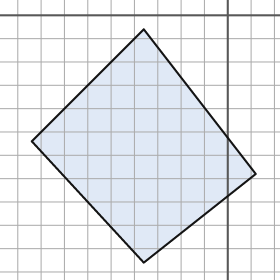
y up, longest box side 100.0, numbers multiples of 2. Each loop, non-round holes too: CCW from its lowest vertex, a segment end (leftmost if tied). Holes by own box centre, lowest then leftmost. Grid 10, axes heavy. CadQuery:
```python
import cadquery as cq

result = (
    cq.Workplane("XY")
    .moveTo(-36.0, -106.0)
    .lineTo(12.0, -68.0)
    .lineTo(-36.0, -6.0)
    .lineTo(-84.0, -54.0)
    .close()
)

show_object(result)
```